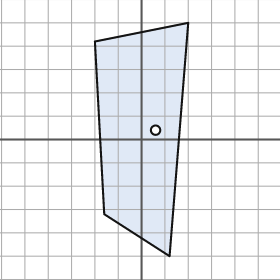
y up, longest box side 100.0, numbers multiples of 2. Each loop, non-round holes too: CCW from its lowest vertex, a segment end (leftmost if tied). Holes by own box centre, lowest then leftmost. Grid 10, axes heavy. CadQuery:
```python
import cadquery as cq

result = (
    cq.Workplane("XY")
    .moveTo(12.0, -50.0)
    .lineTo(20.0, 50.0)
    .lineTo(-20.0, 42.0)
    .lineTo(-16.0, -32.0)
    .close()
    .moveTo(6.0, 4.0)
    .circle(2.0)
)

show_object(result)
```